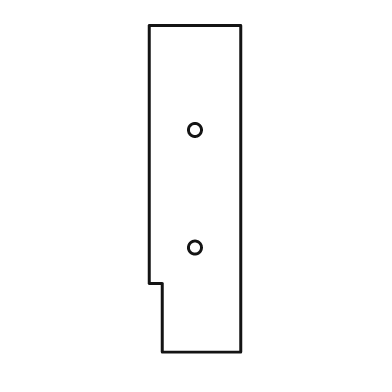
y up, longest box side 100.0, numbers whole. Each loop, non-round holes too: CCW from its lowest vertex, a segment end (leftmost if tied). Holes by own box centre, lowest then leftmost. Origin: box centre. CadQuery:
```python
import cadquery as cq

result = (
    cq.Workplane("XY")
    .moveTo(-10.0, -50.0)
    .lineTo(14.0, -50.0)
    .lineTo(14.0, 50.0)
    .lineTo(-14.0, 50.0)
    .lineTo(-14.0, -29.0)
    .lineTo(-10.0, -29.0)
    .close()
    .moveTo(0.0, -18.0)
    .circle(2.0)
    .moveTo(0.0, 18.0)
    .circle(2.0)
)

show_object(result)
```